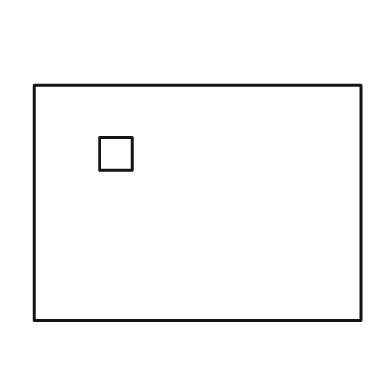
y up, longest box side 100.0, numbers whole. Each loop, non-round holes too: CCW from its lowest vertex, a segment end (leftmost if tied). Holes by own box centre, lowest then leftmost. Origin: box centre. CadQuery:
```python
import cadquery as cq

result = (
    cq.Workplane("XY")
    .moveTo(-50.0, -36.0)
    .lineTo(50.0, -36.0)
    .lineTo(50.0, 36.0)
    .lineTo(-50.0, 36.0)
    .close()
    .moveTo(-30.0, 10.0)
    .lineTo(-20.0, 10.0)
    .lineTo(-20.0, 20.0)
    .lineTo(-30.0, 20.0)
    .close()
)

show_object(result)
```